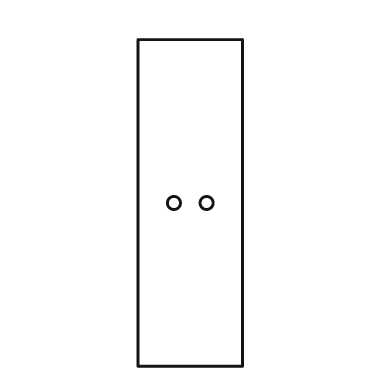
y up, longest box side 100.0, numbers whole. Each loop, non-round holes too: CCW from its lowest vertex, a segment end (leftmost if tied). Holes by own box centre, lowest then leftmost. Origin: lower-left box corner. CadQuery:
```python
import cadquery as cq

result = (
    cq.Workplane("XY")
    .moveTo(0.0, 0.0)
    .lineTo(32.0, 0.0)
    .lineTo(32.0, 100.0)
    .lineTo(0.0, 100.0)
    .close()
    .moveTo(11.0, 50.0)
    .circle(2.0)
    .moveTo(21.0, 50.0)
    .circle(2.0)
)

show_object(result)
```